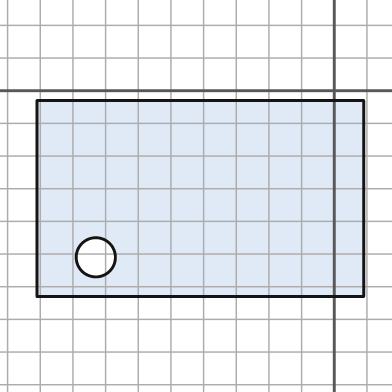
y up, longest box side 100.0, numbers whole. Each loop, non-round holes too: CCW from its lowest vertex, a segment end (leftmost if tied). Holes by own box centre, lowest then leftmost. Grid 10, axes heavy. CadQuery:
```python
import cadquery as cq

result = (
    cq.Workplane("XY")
    .moveTo(-91.0, -63.0)
    .lineTo(9.0, -63.0)
    .lineTo(9.0, -3.0)
    .lineTo(-91.0, -3.0)
    .close()
    .moveTo(-73.0, -51.0)
    .circle(6.0)
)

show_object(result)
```